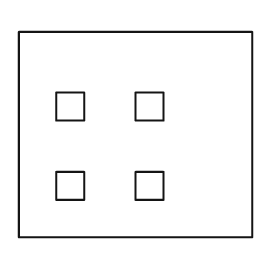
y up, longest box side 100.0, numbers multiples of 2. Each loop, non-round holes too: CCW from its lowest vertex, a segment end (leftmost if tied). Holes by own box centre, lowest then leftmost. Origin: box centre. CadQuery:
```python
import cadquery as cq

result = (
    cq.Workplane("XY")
    .moveTo(-50.0, -44.0)
    .lineTo(50.0, -44.0)
    .lineTo(50.0, 44.0)
    .lineTo(-50.0, 44.0)
    .close()
    .moveTo(-34.0, -28.0)
    .lineTo(-22.0, -28.0)
    .lineTo(-22.0, -16.0)
    .lineTo(-34.0, -16.0)
    .close()
    .moveTo(0.0, -28.0)
    .lineTo(12.0, -28.0)
    .lineTo(12.0, -16.0)
    .lineTo(0.0, -16.0)
    .close()
    .moveTo(-34.0, 6.0)
    .lineTo(-22.0, 6.0)
    .lineTo(-22.0, 18.0)
    .lineTo(-34.0, 18.0)
    .close()
    .moveTo(0.0, 6.0)
    .lineTo(12.0, 6.0)
    .lineTo(12.0, 18.0)
    .lineTo(0.0, 18.0)
    .close()
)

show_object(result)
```